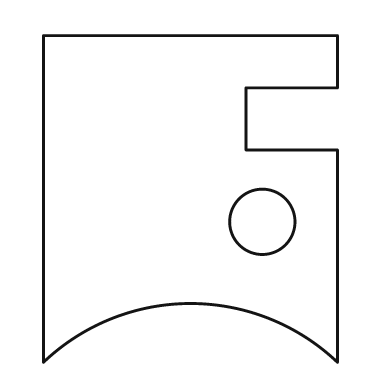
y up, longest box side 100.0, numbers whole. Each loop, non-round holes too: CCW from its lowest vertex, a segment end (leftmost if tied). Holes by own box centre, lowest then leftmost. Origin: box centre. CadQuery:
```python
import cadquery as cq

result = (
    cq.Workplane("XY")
    .moveTo(-45.0, -50.0)
    .threePointArc((0.0, -32.0), (45.0, -50.0))
    .lineTo(45.0, 15.0)
    .lineTo(17.0, 15.0)
    .lineTo(17.0, 34.0)
    .lineTo(45.0, 34.0)
    .lineTo(45.0, 50.0)
    .lineTo(-45.0, 50.0)
    .close()
    .moveTo(22.0, -7.0)
    .circle(10.0)
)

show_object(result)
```